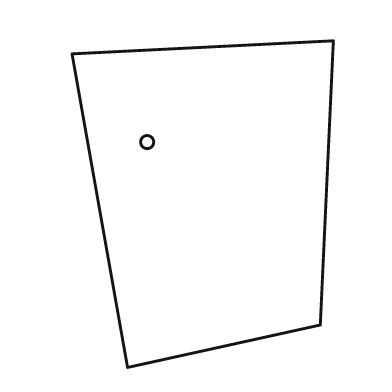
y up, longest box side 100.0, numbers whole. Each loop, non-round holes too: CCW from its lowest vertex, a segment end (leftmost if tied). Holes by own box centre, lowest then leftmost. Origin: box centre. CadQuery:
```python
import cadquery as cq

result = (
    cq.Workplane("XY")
    .moveTo(-23.0, -50.0)
    .lineTo(36.0, -37.0)
    .lineTo(40.0, 50.0)
    .lineTo(-40.0, 46.0)
    .close()
    .moveTo(-17.0, 19.0)
    .circle(2.0)
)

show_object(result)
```